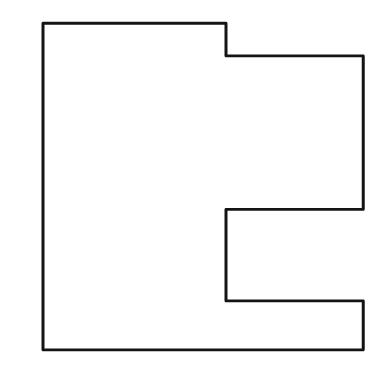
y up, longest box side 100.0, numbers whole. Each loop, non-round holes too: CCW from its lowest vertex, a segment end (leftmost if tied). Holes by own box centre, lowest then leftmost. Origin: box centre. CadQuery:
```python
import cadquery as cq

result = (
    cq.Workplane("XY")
    .moveTo(-49.0, -50.0)
    .lineTo(49.0, -50.0)
    .lineTo(49.0, -35.0)
    .lineTo(7.0, -35.0)
    .lineTo(7.0, -7.0)
    .lineTo(49.0, -7.0)
    .lineTo(49.0, 40.0)
    .lineTo(7.0, 40.0)
    .lineTo(7.0, 50.0)
    .lineTo(-49.0, 50.0)
    .close()
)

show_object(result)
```